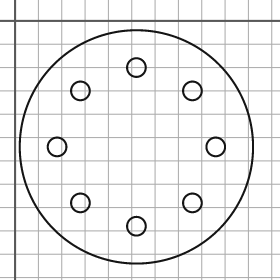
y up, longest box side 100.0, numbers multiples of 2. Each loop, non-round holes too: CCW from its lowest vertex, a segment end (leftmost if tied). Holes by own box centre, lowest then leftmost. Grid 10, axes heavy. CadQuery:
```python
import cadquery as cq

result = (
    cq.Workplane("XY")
    .moveTo(52.0, -54.0)
    .circle(50.0)
    .moveTo(52.0, -88.0)
    .circle(4.0)
    .moveTo(28.0, -78.0)
    .circle(4.0)
    .moveTo(76.0, -78.0)
    .circle(4.0)
    .moveTo(18.0, -54.0)
    .circle(4.0)
    .moveTo(86.0, -54.0)
    .circle(4.0)
    .moveTo(28.0, -30.0)
    .circle(4.0)
    .moveTo(76.0, -30.0)
    .circle(4.0)
    .moveTo(52.0, -20.0)
    .circle(4.0)
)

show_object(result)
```